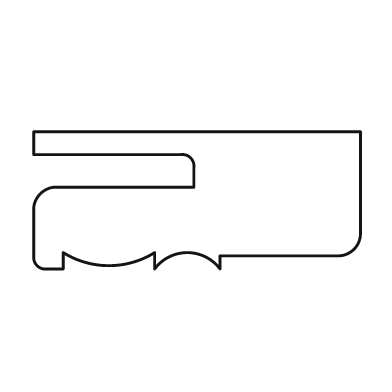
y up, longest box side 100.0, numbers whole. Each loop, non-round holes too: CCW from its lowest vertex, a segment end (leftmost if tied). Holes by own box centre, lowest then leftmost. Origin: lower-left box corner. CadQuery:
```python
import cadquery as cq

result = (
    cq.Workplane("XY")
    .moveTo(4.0, 0.0)
    .lineTo(9.0, 0.0)
    .lineTo(9.0, 5.0)
    .threePointArc((23.0, 1.0), (37.0, 5.0))
    .lineTo(37.0, 0.0)
    .threePointArc((47.0, 5.0), (57.0, 0.0))
    .lineTo(57.0, 4.0)
    .lineTo(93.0, 4.0)
    .threePointArc((98.0, 6.0), (100.0, 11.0))
    .lineTo(100.0, 42.0)
    .lineTo(0.0, 42.0)
    .lineTo(0.0, 35.0)
    .lineTo(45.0, 35.0)
    .threePointArc((48.0, 34.0), (49.0, 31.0))
    .lineTo(49.0, 25.0)
    .lineTo(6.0, 25.0)
    .threePointArc((2.0, 23.0), (0.0, 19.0))
    .lineTo(0.0, 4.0)
    .threePointArc((1.0, 1.0), (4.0, 0.0))
    .close()
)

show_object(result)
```